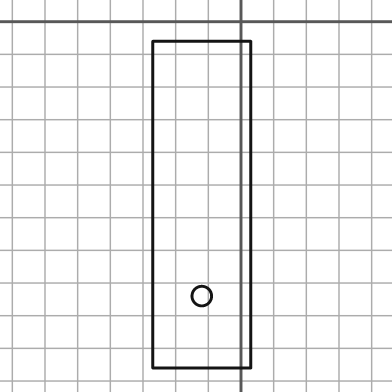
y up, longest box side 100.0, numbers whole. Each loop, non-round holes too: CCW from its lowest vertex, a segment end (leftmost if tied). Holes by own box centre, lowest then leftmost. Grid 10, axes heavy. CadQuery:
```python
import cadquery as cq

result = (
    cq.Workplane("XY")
    .moveTo(-27.0, -106.0)
    .lineTo(3.0, -106.0)
    .lineTo(3.0, -6.0)
    .lineTo(-27.0, -6.0)
    .close()
    .moveTo(-12.0, -84.0)
    .circle(3.0)
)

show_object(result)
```